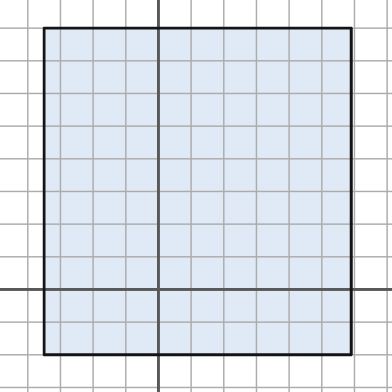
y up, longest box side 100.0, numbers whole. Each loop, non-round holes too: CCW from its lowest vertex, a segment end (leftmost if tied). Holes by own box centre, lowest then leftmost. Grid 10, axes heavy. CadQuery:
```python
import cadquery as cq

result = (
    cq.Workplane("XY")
    .moveTo(-35.0, -20.0)
    .lineTo(59.0, -20.0)
    .lineTo(59.0, 80.0)
    .lineTo(-35.0, 80.0)
    .close()
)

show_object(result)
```